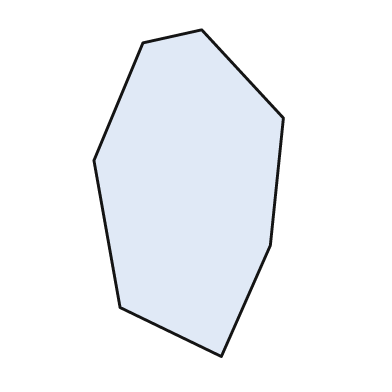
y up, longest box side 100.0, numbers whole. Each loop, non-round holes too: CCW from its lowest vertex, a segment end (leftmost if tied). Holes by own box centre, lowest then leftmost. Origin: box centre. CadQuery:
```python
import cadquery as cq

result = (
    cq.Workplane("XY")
    .moveTo(10.0, -50.0)
    .lineTo(25.0, -16.0)
    .lineTo(29.0, 23.0)
    .lineTo(4.0, 50.0)
    .lineTo(-14.0, 46.0)
    .lineTo(-29.0, 10.0)
    .lineTo(-21.0, -35.0)
    .close()
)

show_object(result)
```